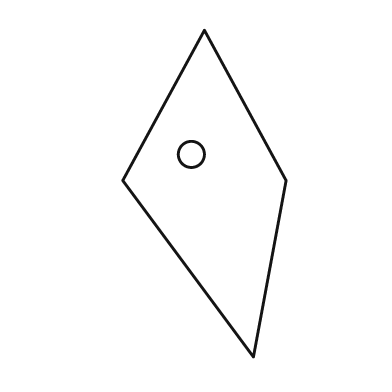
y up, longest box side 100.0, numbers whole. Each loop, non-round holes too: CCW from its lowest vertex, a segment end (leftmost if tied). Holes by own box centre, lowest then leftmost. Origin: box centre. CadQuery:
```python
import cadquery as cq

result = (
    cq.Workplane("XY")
    .moveTo(15.0, -50.0)
    .lineTo(25.0, 4.0)
    .lineTo(0.0, 50.0)
    .lineTo(-25.0, 4.0)
    .close()
    .moveTo(-4.0, 12.0)
    .circle(4.0)
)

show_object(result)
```